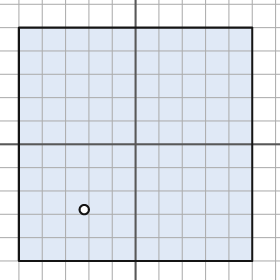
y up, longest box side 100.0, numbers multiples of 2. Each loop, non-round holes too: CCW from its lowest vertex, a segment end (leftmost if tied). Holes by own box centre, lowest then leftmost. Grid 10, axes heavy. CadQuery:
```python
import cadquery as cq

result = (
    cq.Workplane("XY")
    .moveTo(-50.0, -50.0)
    .lineTo(50.0, -50.0)
    .lineTo(50.0, 50.0)
    .lineTo(-50.0, 50.0)
    .close()
    .moveTo(-22.0, -28.0)
    .circle(2.0)
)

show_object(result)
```